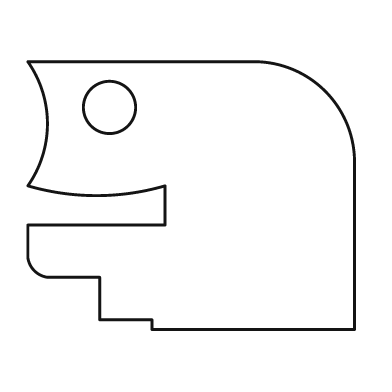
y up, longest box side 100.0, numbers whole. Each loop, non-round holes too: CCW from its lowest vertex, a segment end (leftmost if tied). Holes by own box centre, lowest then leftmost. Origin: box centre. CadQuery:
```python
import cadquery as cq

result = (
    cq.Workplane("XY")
    .moveTo(-12.0, -41.0)
    .lineTo(50.0, -41.0)
    .lineTo(50.0, 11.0)
    .threePointArc((41.0, 32.0), (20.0, 41.0))
    .lineTo(-50.0, 41.0)
    .threePointArc((-44.0, 22.0), (-50.0, 3.0))
    .threePointArc((-29.0, 0.0), (-8.0, 3.0))
    .lineTo(-8.0, -9.0)
    .lineTo(-50.0, -9.0)
    .lineTo(-50.0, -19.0)
    .threePointArc((-48.0, -23.0), (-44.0, -25.0))
    .lineTo(-28.0, -25.0)
    .lineTo(-28.0, -38.0)
    .lineTo(-12.0, -38.0)
    .close()
    .moveTo(-25.0, 27.0)
    .circle(8.0)
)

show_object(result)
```